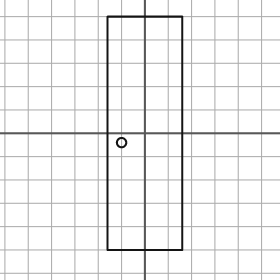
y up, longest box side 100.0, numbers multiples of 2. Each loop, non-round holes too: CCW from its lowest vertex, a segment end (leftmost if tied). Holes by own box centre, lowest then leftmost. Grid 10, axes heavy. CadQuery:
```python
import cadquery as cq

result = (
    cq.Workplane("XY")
    .moveTo(-16.0, -50.0)
    .lineTo(16.0, -50.0)
    .lineTo(16.0, 50.0)
    .lineTo(-16.0, 50.0)
    .close()
    .moveTo(-10.0, -4.0)
    .circle(2.0)
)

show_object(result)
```